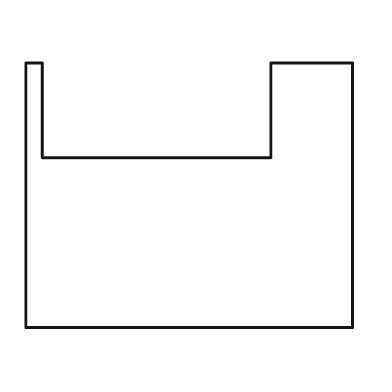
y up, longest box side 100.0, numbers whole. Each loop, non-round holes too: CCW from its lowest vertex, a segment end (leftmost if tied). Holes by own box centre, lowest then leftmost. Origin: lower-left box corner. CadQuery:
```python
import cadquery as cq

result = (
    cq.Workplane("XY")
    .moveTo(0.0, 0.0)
    .lineTo(100.0, 0.0)
    .lineTo(100.0, 81.0)
    .lineTo(75.0, 81.0)
    .lineTo(75.0, 52.0)
    .lineTo(5.0, 52.0)
    .lineTo(5.0, 81.0)
    .lineTo(0.0, 81.0)
    .close()
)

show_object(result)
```